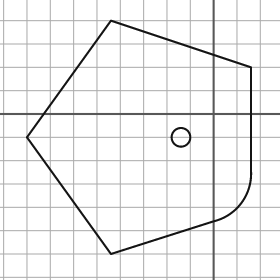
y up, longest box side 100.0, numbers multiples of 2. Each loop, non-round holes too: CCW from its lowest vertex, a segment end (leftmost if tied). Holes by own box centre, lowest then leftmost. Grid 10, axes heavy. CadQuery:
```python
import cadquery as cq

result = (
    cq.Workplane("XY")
    .moveTo(-44.0, -60.0)
    .lineTo(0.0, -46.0)
    .threePointArc((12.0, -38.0), (16.0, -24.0))
    .lineTo(16.0, 20.0)
    .lineTo(-44.0, 40.0)
    .lineTo(-80.0, -10.0)
    .close()
    .moveTo(-14.0, -10.0)
    .circle(4.0)
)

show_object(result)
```